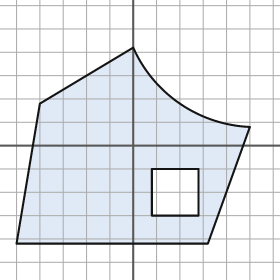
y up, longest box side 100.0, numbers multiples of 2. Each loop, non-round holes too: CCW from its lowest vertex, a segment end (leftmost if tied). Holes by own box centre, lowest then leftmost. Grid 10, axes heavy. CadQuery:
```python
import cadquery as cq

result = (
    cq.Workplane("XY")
    .moveTo(-50.0, -42.0)
    .lineTo(32.0, -42.0)
    .lineTo(50.0, 8.0)
    .threePointArc((20.0, 18.0), (0.0, 42.0))
    .lineTo(-40.0, 18.0)
    .close()
    .moveTo(8.0, -30.0)
    .lineTo(28.0, -30.0)
    .lineTo(28.0, -10.0)
    .lineTo(8.0, -10.0)
    .close()
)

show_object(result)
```